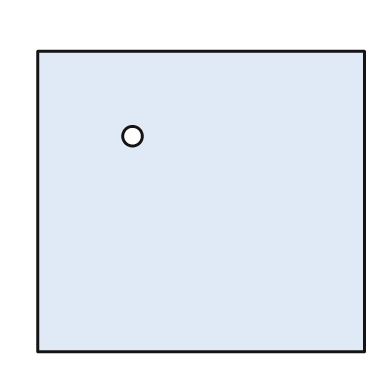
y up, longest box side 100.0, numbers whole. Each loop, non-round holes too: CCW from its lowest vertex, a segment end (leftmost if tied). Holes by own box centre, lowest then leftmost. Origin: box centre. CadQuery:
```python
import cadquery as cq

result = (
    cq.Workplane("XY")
    .moveTo(-50.0, -46.0)
    .lineTo(50.0, -46.0)
    .lineTo(50.0, 46.0)
    .lineTo(-50.0, 46.0)
    .close()
    .moveTo(-21.0, 20.0)
    .circle(3.0)
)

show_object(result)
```